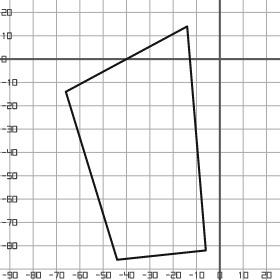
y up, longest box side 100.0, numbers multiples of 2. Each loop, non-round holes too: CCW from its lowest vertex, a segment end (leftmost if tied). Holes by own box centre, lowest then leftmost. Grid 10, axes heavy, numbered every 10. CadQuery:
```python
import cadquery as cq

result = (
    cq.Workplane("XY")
    .moveTo(-44.0, -86.0)
    .lineTo(-6.0, -82.0)
    .lineTo(-14.0, 14.0)
    .lineTo(-66.0, -14.0)
    .close()
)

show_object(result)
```